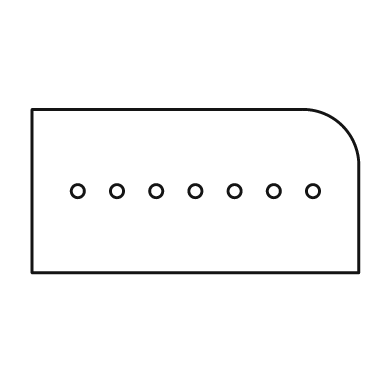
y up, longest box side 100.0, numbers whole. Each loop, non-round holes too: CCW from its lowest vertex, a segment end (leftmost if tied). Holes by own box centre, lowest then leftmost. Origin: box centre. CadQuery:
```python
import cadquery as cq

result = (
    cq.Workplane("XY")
    .moveTo(-50.0, -25.0)
    .lineTo(50.0, -25.0)
    .lineTo(50.0, 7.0)
    .threePointArc((45.0, 20.0), (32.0, 25.0))
    .lineTo(-50.0, 25.0)
    .close()
    .moveTo(-36.0, 0.0)
    .circle(2.0)
    .moveTo(-24.0, 0.0)
    .circle(2.0)
    .moveTo(-12.0, 0.0)
    .circle(2.0)
    .moveTo(0.0, 0.0)
    .circle(2.0)
    .moveTo(12.0, 0.0)
    .circle(2.0)
    .moveTo(24.0, 0.0)
    .circle(2.0)
    .moveTo(36.0, 0.0)
    .circle(2.0)
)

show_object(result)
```